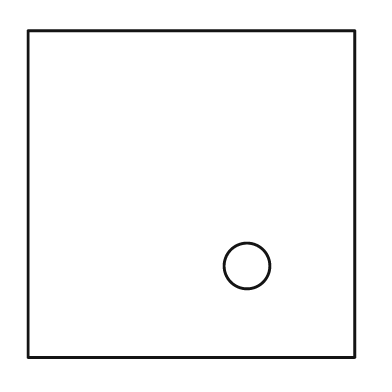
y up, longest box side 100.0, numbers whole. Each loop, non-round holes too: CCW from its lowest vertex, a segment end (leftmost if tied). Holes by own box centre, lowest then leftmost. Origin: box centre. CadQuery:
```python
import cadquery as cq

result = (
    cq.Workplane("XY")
    .moveTo(-50.0, -50.0)
    .lineTo(50.0, -50.0)
    .lineTo(50.0, 50.0)
    .lineTo(-50.0, 50.0)
    .close()
    .moveTo(17.0, -22.0)
    .circle(7.0)
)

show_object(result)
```